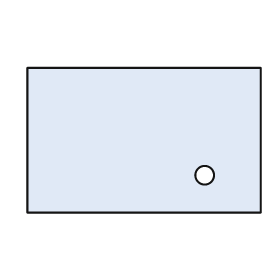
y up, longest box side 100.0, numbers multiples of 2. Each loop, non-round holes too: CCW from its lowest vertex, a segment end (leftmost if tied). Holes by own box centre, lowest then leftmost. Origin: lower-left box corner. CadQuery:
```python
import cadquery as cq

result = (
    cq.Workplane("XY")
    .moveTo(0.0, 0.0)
    .lineTo(100.0, 0.0)
    .lineTo(100.0, 62.0)
    .lineTo(0.0, 62.0)
    .close()
    .moveTo(76.0, 16.0)
    .circle(4.0)
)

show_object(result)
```